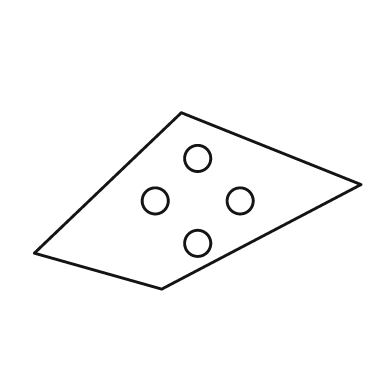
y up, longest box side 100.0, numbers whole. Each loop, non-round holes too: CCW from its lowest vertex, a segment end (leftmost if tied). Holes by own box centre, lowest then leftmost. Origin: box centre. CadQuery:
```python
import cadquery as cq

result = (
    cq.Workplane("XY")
    .moveTo(-11.0, -27.0)
    .lineTo(50.0, 5.0)
    .lineTo(-5.0, 27.0)
    .lineTo(-50.0, -16.0)
    .close()
    .moveTo(0.0, -13.0)
    .circle(4.0)
    .moveTo(-13.0, 0.0)
    .circle(4.0)
    .moveTo(13.0, 0.0)
    .circle(4.0)
    .moveTo(0.0, 13.0)
    .circle(4.0)
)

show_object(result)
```